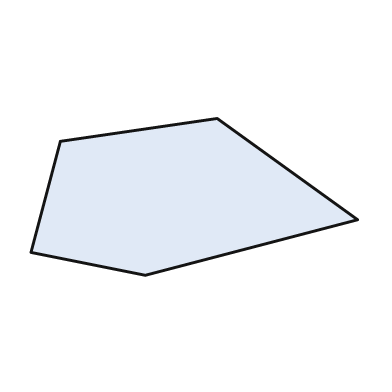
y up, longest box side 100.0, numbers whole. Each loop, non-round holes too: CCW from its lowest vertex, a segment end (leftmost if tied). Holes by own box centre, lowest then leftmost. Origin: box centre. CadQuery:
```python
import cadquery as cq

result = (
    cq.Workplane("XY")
    .moveTo(-15.0, -24.0)
    .lineTo(50.0, -7.0)
    .lineTo(7.0, 24.0)
    .lineTo(-41.0, 17.0)
    .lineTo(-50.0, -17.0)
    .close()
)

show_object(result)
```